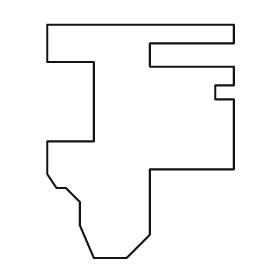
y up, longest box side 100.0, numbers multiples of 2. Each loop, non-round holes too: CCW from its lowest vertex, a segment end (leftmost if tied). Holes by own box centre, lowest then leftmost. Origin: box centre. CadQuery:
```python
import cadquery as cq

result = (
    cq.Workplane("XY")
    .moveTo(-20.0, -50.0)
    .lineTo(-6.0, -50.0)
    .lineTo(4.0, -40.0)
    .lineTo(4.0, -12.0)
    .lineTo(40.0, -12.0)
    .lineTo(40.0, 18.0)
    .lineTo(32.0, 18.0)
    .lineTo(32.0, 24.0)
    .lineTo(40.0, 24.0)
    .lineTo(40.0, 32.0)
    .lineTo(4.0, 32.0)
    .lineTo(4.0, 42.0)
    .lineTo(40.0, 42.0)
    .lineTo(40.0, 50.0)
    .lineTo(-40.0, 50.0)
    .lineTo(-40.0, 34.0)
    .lineTo(-20.0, 34.0)
    .lineTo(-20.0, 0.0)
    .lineTo(-40.0, 0.0)
    .lineTo(-40.0, -14.0)
    .lineTo(-36.0, -20.0)
    .lineTo(-32.0, -20.0)
    .lineTo(-26.0, -26.0)
    .lineTo(-26.0, -36.0)
    .close()
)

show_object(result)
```